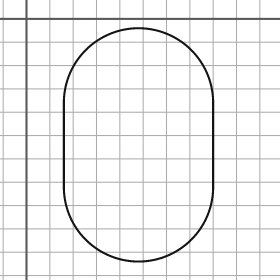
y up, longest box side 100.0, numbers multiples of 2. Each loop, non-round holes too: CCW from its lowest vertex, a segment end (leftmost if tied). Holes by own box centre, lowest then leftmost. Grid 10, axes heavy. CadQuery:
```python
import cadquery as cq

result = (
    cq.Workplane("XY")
    .moveTo(16.0, -72.0)
    .threePointArc((48.0, -104.0), (80.0, -72.0))
    .lineTo(80.0, -36.0)
    .threePointArc((48.0, -4.0), (16.0, -36.0))
    .close()
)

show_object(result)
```